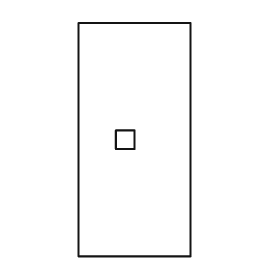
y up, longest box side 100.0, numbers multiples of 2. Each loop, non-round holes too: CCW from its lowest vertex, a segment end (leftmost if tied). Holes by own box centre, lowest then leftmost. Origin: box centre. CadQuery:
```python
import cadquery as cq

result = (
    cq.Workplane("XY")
    .moveTo(-24.0, -50.0)
    .lineTo(24.0, -50.0)
    .lineTo(24.0, 50.0)
    .lineTo(-24.0, 50.0)
    .close()
    .moveTo(-8.0, -4.0)
    .lineTo(0.0, -4.0)
    .lineTo(0.0, 4.0)
    .lineTo(-8.0, 4.0)
    .close()
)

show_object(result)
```